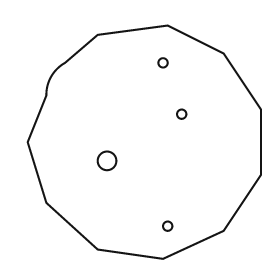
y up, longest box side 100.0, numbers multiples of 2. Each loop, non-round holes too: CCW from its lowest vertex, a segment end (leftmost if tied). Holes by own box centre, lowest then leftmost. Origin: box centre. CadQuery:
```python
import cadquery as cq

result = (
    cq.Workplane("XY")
    .moveTo(8.0, -50.0)
    .lineTo(34.0, -38.0)
    .lineTo(50.0, -14.0)
    .lineTo(50.0, 14.0)
    .lineTo(34.0, 38.0)
    .lineTo(10.0, 50.0)
    .lineTo(-20.0, 46.0)
    .lineTo(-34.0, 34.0)
    .threePointArc((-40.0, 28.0), (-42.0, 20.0))
    .lineTo(-50.0, 0.0)
    .lineTo(-42.0, -26.0)
    .lineTo(-20.0, -46.0)
    .close()
    .moveTo(10.0, -36.0)
    .circle(2.0)
    .moveTo(-16.0, -8.0)
    .circle(4.0)
    .moveTo(16.0, 12.0)
    .circle(2.0)
    .moveTo(8.0, 34.0)
    .circle(2.0)
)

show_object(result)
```